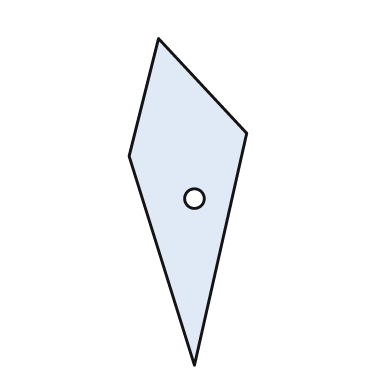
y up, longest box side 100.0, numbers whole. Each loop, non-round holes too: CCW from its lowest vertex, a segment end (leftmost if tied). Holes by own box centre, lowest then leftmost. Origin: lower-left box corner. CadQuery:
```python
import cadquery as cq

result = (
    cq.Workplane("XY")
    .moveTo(20.0, 0.0)
    .lineTo(36.0, 71.0)
    .lineTo(9.0, 100.0)
    .lineTo(0.0, 64.0)
    .close()
    .moveTo(20.0, 51.0)
    .circle(3.0)
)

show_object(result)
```